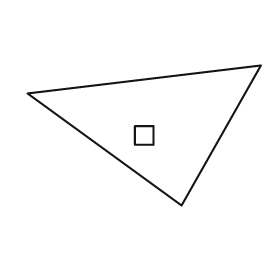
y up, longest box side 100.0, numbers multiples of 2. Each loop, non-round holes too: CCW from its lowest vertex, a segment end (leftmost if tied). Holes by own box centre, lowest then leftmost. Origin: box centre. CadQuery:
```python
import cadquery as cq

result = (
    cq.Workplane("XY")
    .moveTo(16.0, -30.0)
    .lineTo(50.0, 30.0)
    .lineTo(-50.0, 18.0)
    .close()
    .moveTo(-4.0, -4.0)
    .lineTo(4.0, -4.0)
    .lineTo(4.0, 4.0)
    .lineTo(-4.0, 4.0)
    .close()
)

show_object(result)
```